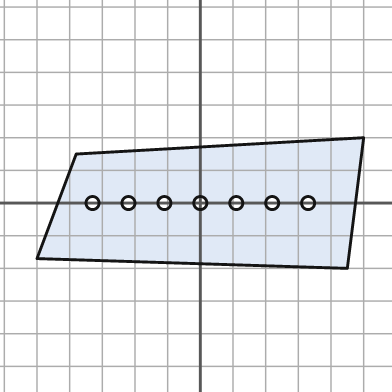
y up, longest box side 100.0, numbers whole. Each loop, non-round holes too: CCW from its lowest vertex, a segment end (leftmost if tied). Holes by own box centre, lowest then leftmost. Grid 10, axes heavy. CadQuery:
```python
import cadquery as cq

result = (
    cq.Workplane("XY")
    .moveTo(45.0, -20.0)
    .lineTo(50.0, 20.0)
    .lineTo(-38.0, 15.0)
    .lineTo(-50.0, -17.0)
    .close()
    .moveTo(-33.0, 0.0)
    .circle(2.0)
    .moveTo(-22.0, 0.0)
    .circle(2.0)
    .moveTo(-11.0, 0.0)
    .circle(2.0)
    .moveTo(0.0, 0.0)
    .circle(2.0)
    .moveTo(11.0, 0.0)
    .circle(2.0)
    .moveTo(22.0, 0.0)
    .circle(2.0)
    .moveTo(33.0, 0.0)
    .circle(2.0)
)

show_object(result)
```